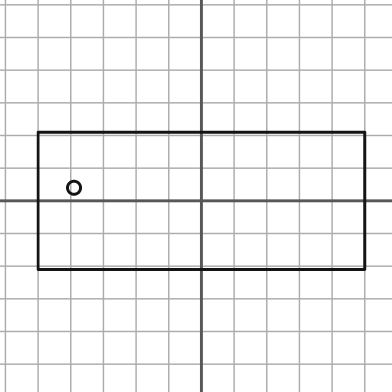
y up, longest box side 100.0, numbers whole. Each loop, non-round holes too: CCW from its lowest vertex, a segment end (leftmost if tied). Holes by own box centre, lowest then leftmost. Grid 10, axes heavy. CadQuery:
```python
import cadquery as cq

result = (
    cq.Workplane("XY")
    .moveTo(-50.0, -21.0)
    .lineTo(50.0, -21.0)
    .lineTo(50.0, 21.0)
    .lineTo(-50.0, 21.0)
    .close()
    .moveTo(-39.0, 4.0)
    .circle(2.0)
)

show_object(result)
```